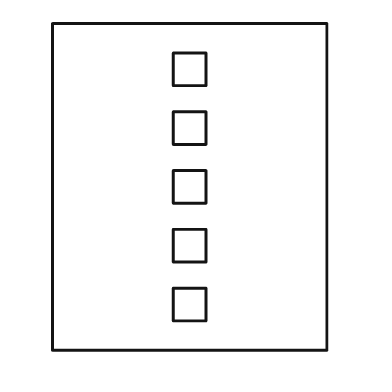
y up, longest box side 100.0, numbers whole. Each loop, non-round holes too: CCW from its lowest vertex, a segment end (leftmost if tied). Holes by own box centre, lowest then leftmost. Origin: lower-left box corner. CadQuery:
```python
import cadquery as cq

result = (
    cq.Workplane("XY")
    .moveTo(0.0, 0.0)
    .lineTo(84.0, 0.0)
    .lineTo(84.0, 100.0)
    .lineTo(0.0, 100.0)
    .close()
    .moveTo(37.0, 9.0)
    .lineTo(47.0, 9.0)
    .lineTo(47.0, 19.0)
    .lineTo(37.0, 19.0)
    .close()
    .moveTo(37.0, 27.0)
    .lineTo(47.0, 27.0)
    .lineTo(47.0, 37.0)
    .lineTo(37.0, 37.0)
    .close()
    .moveTo(37.0, 45.0)
    .lineTo(47.0, 45.0)
    .lineTo(47.0, 55.0)
    .lineTo(37.0, 55.0)
    .close()
    .moveTo(37.0, 63.0)
    .lineTo(47.0, 63.0)
    .lineTo(47.0, 73.0)
    .lineTo(37.0, 73.0)
    .close()
    .moveTo(37.0, 81.0)
    .lineTo(47.0, 81.0)
    .lineTo(47.0, 91.0)
    .lineTo(37.0, 91.0)
    .close()
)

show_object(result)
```